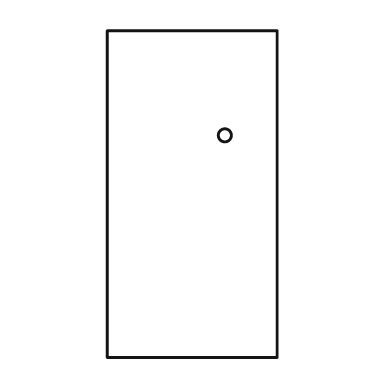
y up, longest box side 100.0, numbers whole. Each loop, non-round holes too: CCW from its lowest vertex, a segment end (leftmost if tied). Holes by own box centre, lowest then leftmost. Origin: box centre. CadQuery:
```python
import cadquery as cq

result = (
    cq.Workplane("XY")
    .moveTo(-26.0, -50.0)
    .lineTo(26.0, -50.0)
    .lineTo(26.0, 50.0)
    .lineTo(-26.0, 50.0)
    .close()
    .moveTo(10.0, 18.0)
    .circle(2.0)
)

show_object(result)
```